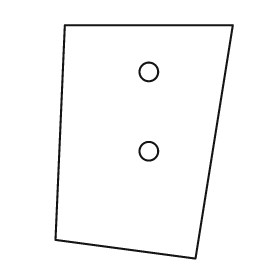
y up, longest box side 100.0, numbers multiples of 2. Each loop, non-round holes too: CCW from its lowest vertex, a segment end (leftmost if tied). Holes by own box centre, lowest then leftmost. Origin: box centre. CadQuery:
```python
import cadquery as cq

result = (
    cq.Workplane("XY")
    .moveTo(22.0, -50.0)
    .lineTo(38.0, 50.0)
    .lineTo(-34.0, 50.0)
    .lineTo(-38.0, -42.0)
    .close()
    .moveTo(2.0, -4.0)
    .circle(4.0)
    .moveTo(2.0, 30.0)
    .circle(4.0)
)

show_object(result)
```